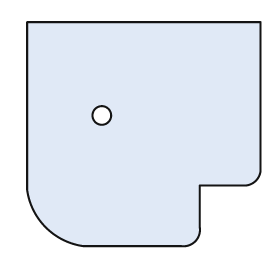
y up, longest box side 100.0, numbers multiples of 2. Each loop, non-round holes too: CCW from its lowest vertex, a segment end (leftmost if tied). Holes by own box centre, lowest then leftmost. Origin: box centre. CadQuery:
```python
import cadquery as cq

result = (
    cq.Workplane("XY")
    .moveTo(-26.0, -48.0)
    .lineTo(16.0, -48.0)
    .threePointArc((22.0, -46.0), (24.0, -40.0))
    .lineTo(24.0, -22.0)
    .lineTo(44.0, -22.0)
    .threePointArc((48.0, -20.0), (50.0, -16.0))
    .lineTo(50.0, 48.0)
    .lineTo(-50.0, 48.0)
    .lineTo(-50.0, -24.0)
    .threePointArc((-42.0, -40.0), (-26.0, -48.0))
    .close()
    .moveTo(-18.0, 8.0)
    .circle(4.0)
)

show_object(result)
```